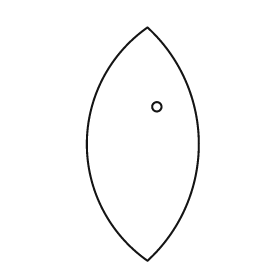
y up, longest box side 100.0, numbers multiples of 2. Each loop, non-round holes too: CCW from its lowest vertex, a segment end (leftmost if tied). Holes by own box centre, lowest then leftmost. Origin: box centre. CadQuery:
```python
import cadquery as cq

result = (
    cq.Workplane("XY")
    .moveTo(2.0, -50.0)
    .threePointArc((24.0, 0.0), (2.0, 50.0))
    .threePointArc((-24.0, 0.0), (2.0, -50.0))
    .close()
    .moveTo(6.0, 16.0)
    .circle(2.0)
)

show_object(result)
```